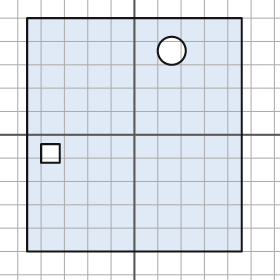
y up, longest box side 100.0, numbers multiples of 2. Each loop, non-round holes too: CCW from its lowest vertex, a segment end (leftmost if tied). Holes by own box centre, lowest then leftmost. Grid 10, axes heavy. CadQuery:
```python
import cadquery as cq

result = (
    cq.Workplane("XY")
    .moveTo(-46.0, -50.0)
    .lineTo(46.0, -50.0)
    .lineTo(46.0, 50.0)
    .lineTo(-46.0, 50.0)
    .close()
    .moveTo(-40.0, -12.0)
    .lineTo(-32.0, -12.0)
    .lineTo(-32.0, -4.0)
    .lineTo(-40.0, -4.0)
    .close()
    .moveTo(16.0, 36.0)
    .circle(6.0)
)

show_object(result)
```